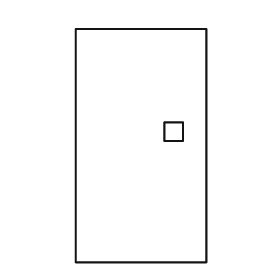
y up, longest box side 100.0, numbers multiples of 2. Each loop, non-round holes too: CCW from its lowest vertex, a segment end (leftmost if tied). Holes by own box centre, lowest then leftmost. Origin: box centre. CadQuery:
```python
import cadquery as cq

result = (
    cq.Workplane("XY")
    .moveTo(-28.0, -50.0)
    .lineTo(28.0, -50.0)
    .lineTo(28.0, 50.0)
    .lineTo(-28.0, 50.0)
    .close()
    .moveTo(10.0, 2.0)
    .lineTo(18.0, 2.0)
    .lineTo(18.0, 10.0)
    .lineTo(10.0, 10.0)
    .close()
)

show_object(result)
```